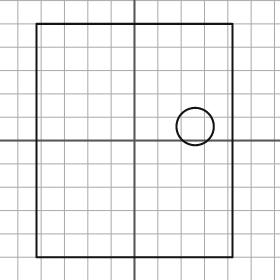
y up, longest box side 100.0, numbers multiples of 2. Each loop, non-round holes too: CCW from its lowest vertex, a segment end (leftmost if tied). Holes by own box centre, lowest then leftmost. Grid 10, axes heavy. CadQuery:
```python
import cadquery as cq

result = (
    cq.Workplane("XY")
    .moveTo(-42.0, -50.0)
    .lineTo(42.0, -50.0)
    .lineTo(42.0, 50.0)
    .lineTo(-42.0, 50.0)
    .close()
    .moveTo(26.0, 6.0)
    .circle(8.0)
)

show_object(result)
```